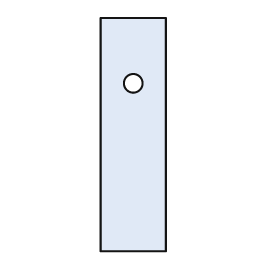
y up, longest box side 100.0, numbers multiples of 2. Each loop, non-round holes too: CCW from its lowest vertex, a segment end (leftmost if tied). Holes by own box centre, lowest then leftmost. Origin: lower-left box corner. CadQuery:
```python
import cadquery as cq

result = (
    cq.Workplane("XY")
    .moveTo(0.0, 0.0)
    .lineTo(28.0, 0.0)
    .lineTo(28.0, 100.0)
    .lineTo(0.0, 100.0)
    .close()
    .moveTo(14.0, 72.0)
    .circle(4.0)
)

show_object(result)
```